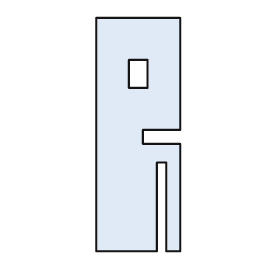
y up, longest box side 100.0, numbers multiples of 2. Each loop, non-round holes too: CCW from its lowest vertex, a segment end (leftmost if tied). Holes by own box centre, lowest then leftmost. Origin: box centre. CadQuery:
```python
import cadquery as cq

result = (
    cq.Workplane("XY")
    .moveTo(-18.0, -50.0)
    .lineTo(8.0, -50.0)
    .lineTo(8.0, -12.0)
    .lineTo(12.0, -12.0)
    .lineTo(12.0, -50.0)
    .lineTo(18.0, -50.0)
    .lineTo(18.0, -4.0)
    .lineTo(2.0, -4.0)
    .lineTo(2.0, 2.0)
    .lineTo(18.0, 2.0)
    .lineTo(18.0, 50.0)
    .lineTo(-18.0, 50.0)
    .close()
    .moveTo(-4.0, 20.0)
    .lineTo(4.0, 20.0)
    .lineTo(4.0, 32.0)
    .lineTo(-4.0, 32.0)
    .close()
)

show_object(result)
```